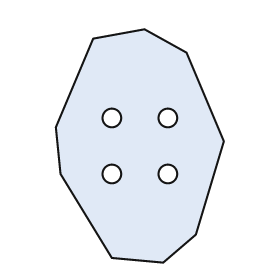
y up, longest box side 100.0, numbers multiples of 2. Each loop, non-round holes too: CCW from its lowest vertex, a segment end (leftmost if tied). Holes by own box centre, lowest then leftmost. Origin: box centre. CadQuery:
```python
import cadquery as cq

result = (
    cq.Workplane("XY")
    .moveTo(10.0, -50.0)
    .lineTo(24.0, -38.0)
    .lineTo(36.0, 2.0)
    .lineTo(20.0, 40.0)
    .lineTo(2.0, 50.0)
    .lineTo(-20.0, 46.0)
    .lineTo(-36.0, 8.0)
    .lineTo(-34.0, -12.0)
    .lineTo(-12.0, -48.0)
    .close()
    .moveTo(-12.0, -12.0)
    .circle(4.0)
    .moveTo(12.0, -12.0)
    .circle(4.0)
    .moveTo(-12.0, 12.0)
    .circle(4.0)
    .moveTo(12.0, 12.0)
    .circle(4.0)
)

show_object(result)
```